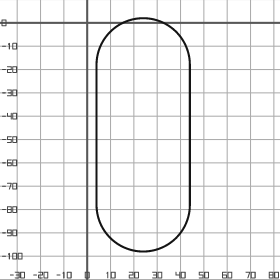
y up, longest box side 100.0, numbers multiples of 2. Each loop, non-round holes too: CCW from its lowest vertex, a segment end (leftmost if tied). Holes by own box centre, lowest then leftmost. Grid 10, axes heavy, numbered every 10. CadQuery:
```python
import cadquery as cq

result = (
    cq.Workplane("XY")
    .moveTo(4.0, -78.0)
    .threePointArc((24.0, -98.0), (44.0, -78.0))
    .lineTo(44.0, -18.0)
    .threePointArc((24.0, 2.0), (4.0, -18.0))
    .close()
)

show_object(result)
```